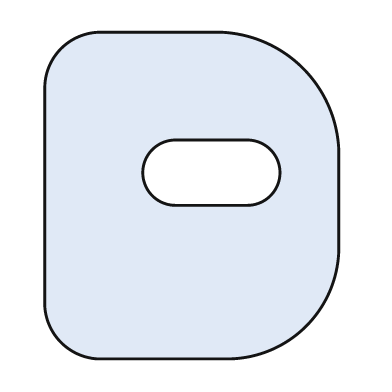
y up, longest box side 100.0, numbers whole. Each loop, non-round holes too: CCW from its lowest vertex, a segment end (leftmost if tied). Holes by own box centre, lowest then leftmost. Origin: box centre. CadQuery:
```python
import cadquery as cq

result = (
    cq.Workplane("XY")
    .moveTo(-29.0, -50.0)
    .lineTo(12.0, -50.0)
    .threePointArc((35.0, -40.0), (45.0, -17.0))
    .lineTo(45.0, 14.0)
    .threePointArc((34.0, 39.0), (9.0, 50.0))
    .lineTo(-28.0, 50.0)
    .threePointArc((-40.0, 45.0), (-45.0, 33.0))
    .lineTo(-45.0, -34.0)
    .threePointArc((-40.0, -45.0), (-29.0, -50.0))
    .close()
    .moveTo(-5.0, -3.0)
    .lineTo(17.0, -3.0)
    .threePointArc((27.0, 7.0), (17.0, 17.0))
    .lineTo(-5.0, 17.0)
    .threePointArc((-15.0, 7.0), (-5.0, -3.0))
    .close()
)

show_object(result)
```